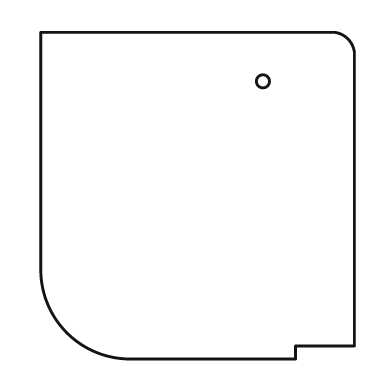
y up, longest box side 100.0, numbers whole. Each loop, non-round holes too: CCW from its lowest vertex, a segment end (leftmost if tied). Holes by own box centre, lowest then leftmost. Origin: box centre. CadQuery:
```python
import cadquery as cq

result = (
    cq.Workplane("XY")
    .moveTo(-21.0, -50.0)
    .lineTo(30.0, -50.0)
    .lineTo(30.0, -46.0)
    .lineTo(48.0, -46.0)
    .lineTo(48.0, 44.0)
    .threePointArc((46.0, 48.0), (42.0, 50.0))
    .lineTo(-48.0, 50.0)
    .lineTo(-48.0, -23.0)
    .threePointArc((-40.0, -42.0), (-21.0, -50.0))
    .close()
    .moveTo(20.0, 35.0)
    .circle(2.0)
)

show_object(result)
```